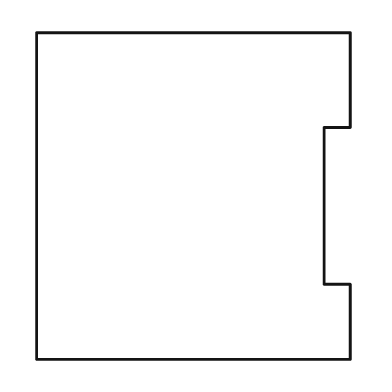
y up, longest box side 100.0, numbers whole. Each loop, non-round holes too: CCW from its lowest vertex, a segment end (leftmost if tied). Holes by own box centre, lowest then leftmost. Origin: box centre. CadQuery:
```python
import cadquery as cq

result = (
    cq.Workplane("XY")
    .moveTo(-48.0, -50.0)
    .lineTo(48.0, -50.0)
    .lineTo(48.0, -27.0)
    .lineTo(40.0, -27.0)
    .lineTo(40.0, 21.0)
    .lineTo(48.0, 21.0)
    .lineTo(48.0, 50.0)
    .lineTo(-48.0, 50.0)
    .close()
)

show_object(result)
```